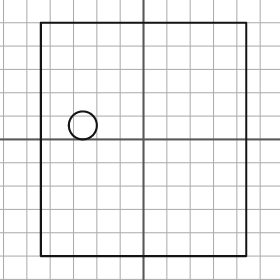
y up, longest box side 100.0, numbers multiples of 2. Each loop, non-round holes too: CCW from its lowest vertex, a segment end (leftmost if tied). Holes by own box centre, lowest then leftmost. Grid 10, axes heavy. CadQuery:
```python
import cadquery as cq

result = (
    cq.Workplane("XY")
    .moveTo(-44.0, -50.0)
    .lineTo(44.0, -50.0)
    .lineTo(44.0, 50.0)
    .lineTo(-44.0, 50.0)
    .close()
    .moveTo(-26.0, 6.0)
    .circle(6.0)
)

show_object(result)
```